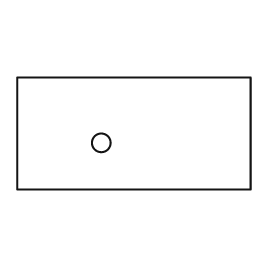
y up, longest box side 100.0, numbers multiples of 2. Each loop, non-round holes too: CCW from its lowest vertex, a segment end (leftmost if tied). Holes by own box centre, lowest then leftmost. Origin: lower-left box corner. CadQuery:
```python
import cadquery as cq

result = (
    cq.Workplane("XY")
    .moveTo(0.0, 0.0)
    .lineTo(100.0, 0.0)
    .lineTo(100.0, 48.0)
    .lineTo(0.0, 48.0)
    .close()
    .moveTo(36.0, 20.0)
    .circle(4.0)
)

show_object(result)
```